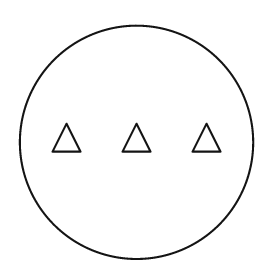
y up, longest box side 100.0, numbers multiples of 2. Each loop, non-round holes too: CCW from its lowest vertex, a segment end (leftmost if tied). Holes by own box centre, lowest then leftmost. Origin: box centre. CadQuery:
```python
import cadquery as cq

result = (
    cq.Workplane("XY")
    .moveTo(0.0, 0.0)
    .circle(50.0)
    .moveTo(-36.0, -4.0)
    .lineTo(-24.0, -4.0)
    .lineTo(-30.0, 8.0)
    .close()
    .moveTo(-6.0, -4.0)
    .lineTo(6.0, -4.0)
    .lineTo(0.0, 8.0)
    .close()
    .moveTo(24.0, -4.0)
    .lineTo(36.0, -4.0)
    .lineTo(30.0, 8.0)
    .close()
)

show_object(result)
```